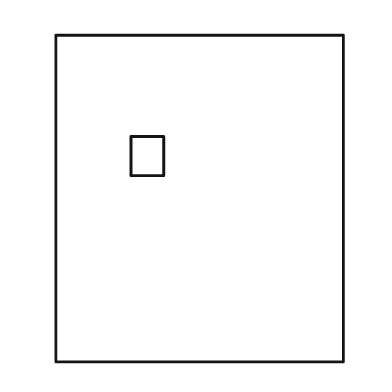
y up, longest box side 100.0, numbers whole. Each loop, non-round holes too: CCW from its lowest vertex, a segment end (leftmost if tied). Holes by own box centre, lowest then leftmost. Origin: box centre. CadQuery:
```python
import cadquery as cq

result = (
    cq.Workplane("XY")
    .moveTo(-44.0, -50.0)
    .lineTo(44.0, -50.0)
    .lineTo(44.0, 50.0)
    .lineTo(-44.0, 50.0)
    .close()
    .moveTo(-21.0, 7.0)
    .lineTo(-11.0, 7.0)
    .lineTo(-11.0, 19.0)
    .lineTo(-21.0, 19.0)
    .close()
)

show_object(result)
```